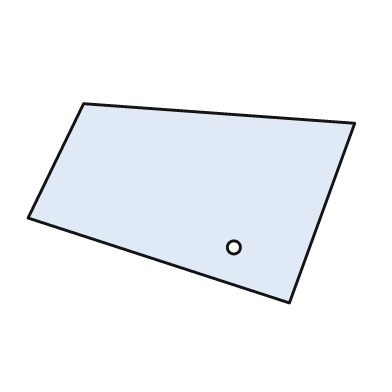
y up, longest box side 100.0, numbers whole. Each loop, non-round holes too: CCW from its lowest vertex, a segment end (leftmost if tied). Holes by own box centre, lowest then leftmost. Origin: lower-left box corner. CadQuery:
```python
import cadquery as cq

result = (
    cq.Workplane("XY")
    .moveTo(80.0, 0.0)
    .lineTo(100.0, 55.0)
    .lineTo(17.0, 61.0)
    .lineTo(0.0, 26.0)
    .close()
    .moveTo(63.0, 17.0)
    .circle(2.0)
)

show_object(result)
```